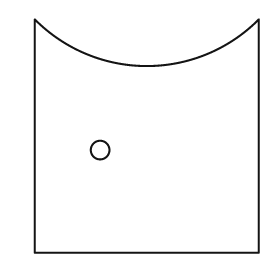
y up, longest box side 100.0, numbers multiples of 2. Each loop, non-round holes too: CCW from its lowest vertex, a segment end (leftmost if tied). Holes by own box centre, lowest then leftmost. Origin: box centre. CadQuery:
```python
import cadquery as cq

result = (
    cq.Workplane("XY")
    .moveTo(-48.0, -50.0)
    .lineTo(48.0, -50.0)
    .lineTo(48.0, 50.0)
    .threePointArc((0.0, 30.0), (-48.0, 50.0))
    .close()
    .moveTo(-20.0, -6.0)
    .circle(4.0)
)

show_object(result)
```